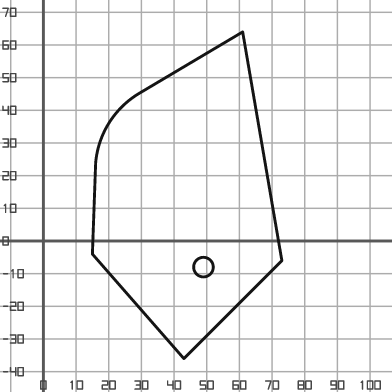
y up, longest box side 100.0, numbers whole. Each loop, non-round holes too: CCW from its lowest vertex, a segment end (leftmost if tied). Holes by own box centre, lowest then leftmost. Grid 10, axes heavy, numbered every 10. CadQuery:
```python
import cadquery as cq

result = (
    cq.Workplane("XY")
    .moveTo(43.0, -36.0)
    .lineTo(73.0, -6.0)
    .lineTo(61.0, 64.0)
    .lineTo(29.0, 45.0)
    .threePointArc((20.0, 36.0), (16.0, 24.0))
    .lineTo(15.0, -4.0)
    .close()
    .moveTo(49.0, -8.0)
    .circle(3.0)
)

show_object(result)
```